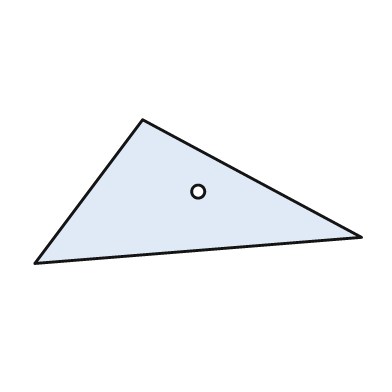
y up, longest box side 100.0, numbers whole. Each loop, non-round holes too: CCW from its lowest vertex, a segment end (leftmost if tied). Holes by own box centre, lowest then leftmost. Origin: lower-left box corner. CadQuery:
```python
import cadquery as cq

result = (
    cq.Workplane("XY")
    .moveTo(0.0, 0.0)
    .lineTo(100.0, 8.0)
    .lineTo(33.0, 44.0)
    .close()
    .moveTo(50.0, 22.0)
    .circle(2.0)
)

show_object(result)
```